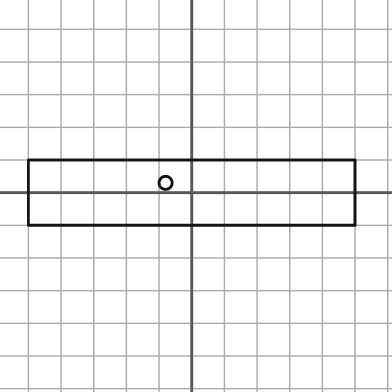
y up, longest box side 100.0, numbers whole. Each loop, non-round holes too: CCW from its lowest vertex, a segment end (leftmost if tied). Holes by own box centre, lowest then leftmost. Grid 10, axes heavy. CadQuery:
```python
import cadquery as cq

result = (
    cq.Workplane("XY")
    .moveTo(-50.0, -10.0)
    .lineTo(50.0, -10.0)
    .lineTo(50.0, 10.0)
    .lineTo(-50.0, 10.0)
    .close()
    .moveTo(-8.0, 3.0)
    .circle(2.0)
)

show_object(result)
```